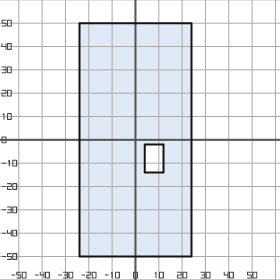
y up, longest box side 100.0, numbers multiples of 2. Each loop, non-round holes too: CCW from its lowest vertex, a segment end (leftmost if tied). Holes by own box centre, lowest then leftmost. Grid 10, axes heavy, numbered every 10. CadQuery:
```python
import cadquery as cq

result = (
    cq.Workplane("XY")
    .moveTo(-24.0, -50.0)
    .lineTo(24.0, -50.0)
    .lineTo(24.0, 50.0)
    .lineTo(-24.0, 50.0)
    .close()
    .moveTo(4.0, -14.0)
    .lineTo(12.0, -14.0)
    .lineTo(12.0, -2.0)
    .lineTo(4.0, -2.0)
    .close()
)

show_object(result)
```